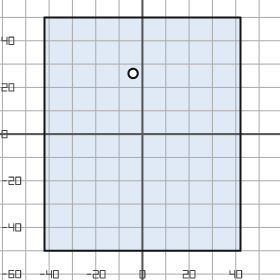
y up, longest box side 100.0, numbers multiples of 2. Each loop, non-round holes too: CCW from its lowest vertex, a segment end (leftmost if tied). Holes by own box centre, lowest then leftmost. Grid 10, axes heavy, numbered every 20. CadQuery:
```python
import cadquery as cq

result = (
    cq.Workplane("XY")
    .moveTo(-42.0, -50.0)
    .lineTo(42.0, -50.0)
    .lineTo(42.0, 50.0)
    .lineTo(-42.0, 50.0)
    .close()
    .moveTo(-4.0, 26.0)
    .circle(2.0)
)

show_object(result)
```